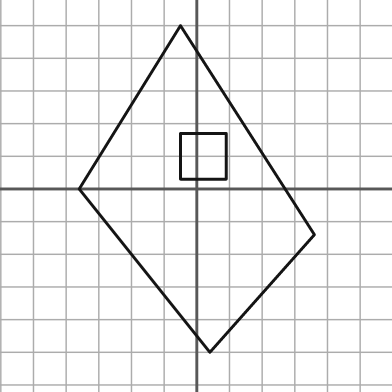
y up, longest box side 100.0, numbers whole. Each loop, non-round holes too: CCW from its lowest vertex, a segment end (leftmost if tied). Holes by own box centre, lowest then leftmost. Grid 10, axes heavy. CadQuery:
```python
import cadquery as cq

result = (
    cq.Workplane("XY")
    .moveTo(4.0, -50.0)
    .lineTo(36.0, -14.0)
    .lineTo(-5.0, 50.0)
    .lineTo(-36.0, 0.0)
    .close()
    .moveTo(-5.0, 3.0)
    .lineTo(9.0, 3.0)
    .lineTo(9.0, 17.0)
    .lineTo(-5.0, 17.0)
    .close()
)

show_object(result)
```